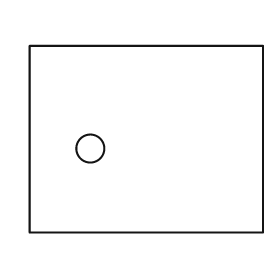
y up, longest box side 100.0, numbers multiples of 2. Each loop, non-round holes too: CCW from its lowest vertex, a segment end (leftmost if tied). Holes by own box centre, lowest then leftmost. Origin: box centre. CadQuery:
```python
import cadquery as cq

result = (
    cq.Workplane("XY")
    .moveTo(-50.0, -40.0)
    .lineTo(50.0, -40.0)
    .lineTo(50.0, 40.0)
    .lineTo(-50.0, 40.0)
    .close()
    .moveTo(-24.0, -4.0)
    .circle(6.0)
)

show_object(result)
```